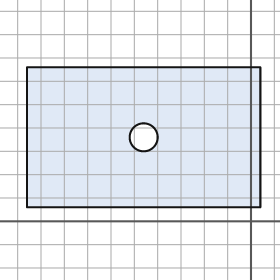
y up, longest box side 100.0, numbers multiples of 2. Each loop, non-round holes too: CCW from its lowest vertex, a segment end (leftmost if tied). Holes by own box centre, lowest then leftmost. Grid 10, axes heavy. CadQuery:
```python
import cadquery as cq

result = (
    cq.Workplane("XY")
    .moveTo(-96.0, 6.0)
    .lineTo(4.0, 6.0)
    .lineTo(4.0, 66.0)
    .lineTo(-96.0, 66.0)
    .close()
    .moveTo(-46.0, 36.0)
    .circle(6.0)
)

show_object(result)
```